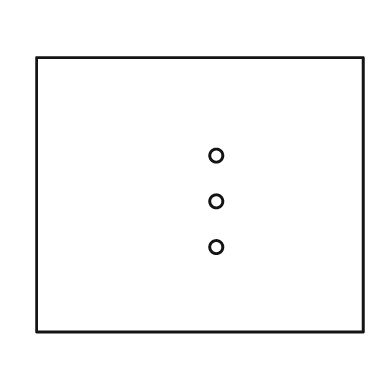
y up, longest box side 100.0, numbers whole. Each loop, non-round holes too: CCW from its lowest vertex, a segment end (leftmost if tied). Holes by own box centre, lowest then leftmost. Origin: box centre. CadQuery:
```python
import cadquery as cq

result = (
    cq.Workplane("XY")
    .moveTo(-50.0, -42.0)
    .lineTo(50.0, -42.0)
    .lineTo(50.0, 42.0)
    .lineTo(-50.0, 42.0)
    .close()
    .moveTo(5.0, -16.0)
    .circle(2.0)
    .moveTo(5.0, -2.0)
    .circle(2.0)
    .moveTo(5.0, 12.0)
    .circle(2.0)
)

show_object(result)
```